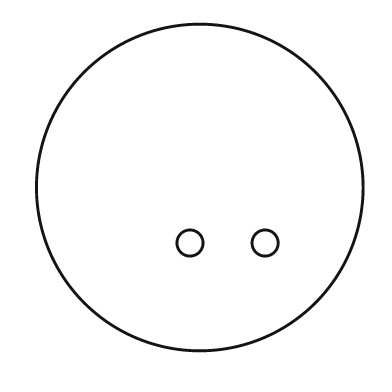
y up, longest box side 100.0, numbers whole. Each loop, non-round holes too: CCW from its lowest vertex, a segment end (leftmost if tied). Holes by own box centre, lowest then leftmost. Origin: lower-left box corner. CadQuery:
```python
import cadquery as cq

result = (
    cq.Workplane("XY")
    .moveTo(50.0, 50.0)
    .circle(50.0)
    .moveTo(47.0, 33.0)
    .circle(4.0)
    .moveTo(70.0, 33.0)
    .circle(4.0)
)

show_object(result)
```